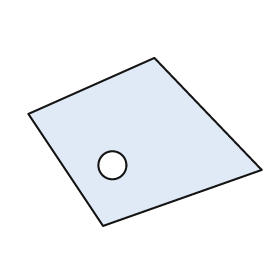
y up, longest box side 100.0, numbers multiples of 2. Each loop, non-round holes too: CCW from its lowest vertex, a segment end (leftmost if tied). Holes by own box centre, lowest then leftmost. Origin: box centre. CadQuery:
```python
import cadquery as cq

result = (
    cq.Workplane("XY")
    .moveTo(-18.0, -36.0)
    .lineTo(50.0, -12.0)
    .lineTo(4.0, 36.0)
    .lineTo(-50.0, 12.0)
    .close()
    .moveTo(-14.0, -10.0)
    .circle(6.0)
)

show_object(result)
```